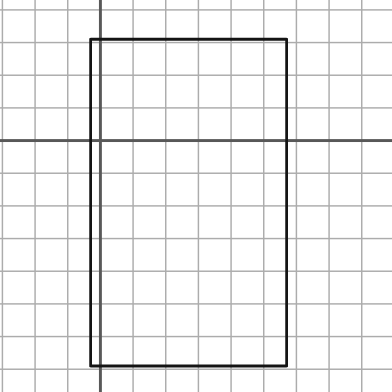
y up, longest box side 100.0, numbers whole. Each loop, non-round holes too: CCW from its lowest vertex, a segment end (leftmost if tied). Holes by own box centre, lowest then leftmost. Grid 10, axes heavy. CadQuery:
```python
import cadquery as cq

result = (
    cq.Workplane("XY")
    .moveTo(-3.0, -69.0)
    .lineTo(57.0, -69.0)
    .lineTo(57.0, 31.0)
    .lineTo(-3.0, 31.0)
    .close()
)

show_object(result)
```